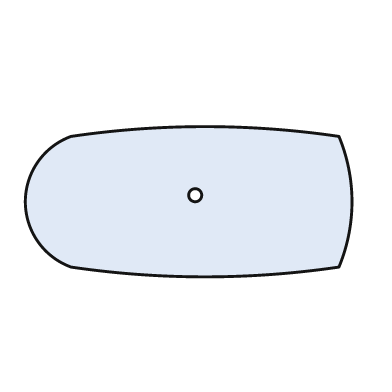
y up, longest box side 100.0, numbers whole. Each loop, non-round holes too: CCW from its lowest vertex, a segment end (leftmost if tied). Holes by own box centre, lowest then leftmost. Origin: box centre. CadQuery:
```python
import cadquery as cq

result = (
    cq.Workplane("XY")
    .moveTo(-36.0, -20.0)
    .threePointArc((5.0, -23.0), (46.0, -20.0))
    .threePointArc((50.0, 0.0), (46.0, 20.0))
    .threePointArc((5.0, 23.0), (-36.0, 20.0))
    .threePointArc((-50.0, 0.0), (-36.0, -20.0))
    .close()
    .moveTo(2.0, 2.0)
    .circle(2.0)
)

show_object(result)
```